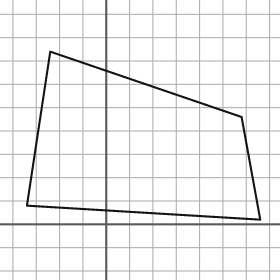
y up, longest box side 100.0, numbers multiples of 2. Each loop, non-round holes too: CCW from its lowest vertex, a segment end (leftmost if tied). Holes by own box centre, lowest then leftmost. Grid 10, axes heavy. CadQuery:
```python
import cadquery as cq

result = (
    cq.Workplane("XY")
    .moveTo(66.0, 2.0)
    .lineTo(58.0, 46.0)
    .lineTo(-24.0, 74.0)
    .lineTo(-34.0, 8.0)
    .close()
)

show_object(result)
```